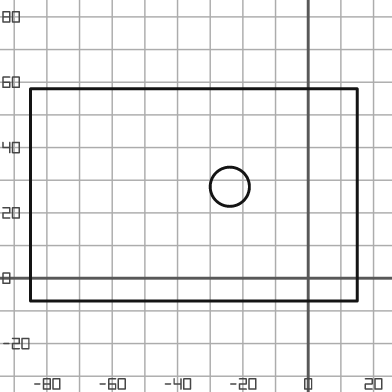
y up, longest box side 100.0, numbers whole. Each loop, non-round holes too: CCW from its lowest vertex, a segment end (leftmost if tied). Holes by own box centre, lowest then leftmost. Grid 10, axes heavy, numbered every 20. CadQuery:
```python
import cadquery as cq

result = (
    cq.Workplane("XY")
    .moveTo(-85.0, -7.0)
    .lineTo(15.0, -7.0)
    .lineTo(15.0, 58.0)
    .lineTo(-85.0, 58.0)
    .close()
    .moveTo(-24.0, 28.0)
    .circle(6.0)
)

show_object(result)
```